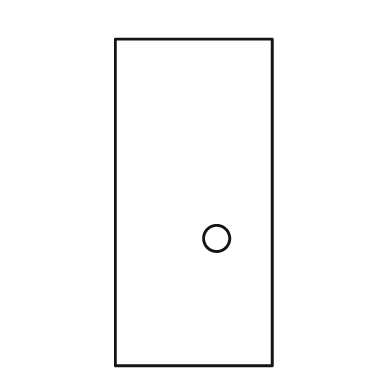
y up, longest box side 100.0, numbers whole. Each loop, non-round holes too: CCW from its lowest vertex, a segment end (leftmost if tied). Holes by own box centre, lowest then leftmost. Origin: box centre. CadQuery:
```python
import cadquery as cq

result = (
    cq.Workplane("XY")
    .moveTo(-24.0, -50.0)
    .lineTo(24.0, -50.0)
    .lineTo(24.0, 50.0)
    .lineTo(-24.0, 50.0)
    .close()
    .moveTo(7.0, -11.0)
    .circle(4.0)
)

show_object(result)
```